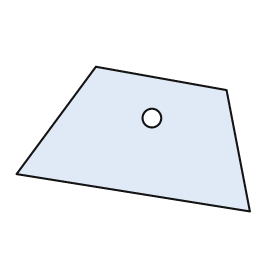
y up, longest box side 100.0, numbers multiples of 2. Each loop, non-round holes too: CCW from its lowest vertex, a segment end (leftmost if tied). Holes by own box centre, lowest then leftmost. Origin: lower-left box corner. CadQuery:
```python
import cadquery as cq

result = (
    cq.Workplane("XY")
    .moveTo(100.0, 0.0)
    .lineTo(90.0, 52.0)
    .lineTo(34.0, 62.0)
    .lineTo(0.0, 16.0)
    .close()
    .moveTo(58.0, 40.0)
    .circle(4.0)
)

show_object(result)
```